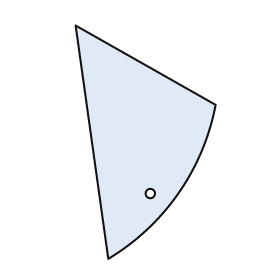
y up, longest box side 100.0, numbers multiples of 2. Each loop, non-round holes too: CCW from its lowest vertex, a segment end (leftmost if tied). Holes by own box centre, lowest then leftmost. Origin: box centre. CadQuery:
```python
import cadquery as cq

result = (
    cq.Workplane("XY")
    .moveTo(-16.0, -50.0)
    .threePointArc((14.0, -22.0), (30.0, 16.0))
    .lineTo(-30.0, 50.0)
    .close()
    .moveTo(2.0, -22.0)
    .circle(2.0)
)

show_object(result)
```